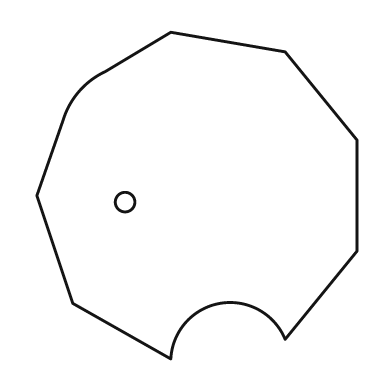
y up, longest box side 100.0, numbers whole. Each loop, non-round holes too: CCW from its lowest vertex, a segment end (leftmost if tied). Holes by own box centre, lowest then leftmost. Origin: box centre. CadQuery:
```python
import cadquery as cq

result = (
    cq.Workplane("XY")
    .moveTo(-8.0, -50.0)
    .threePointArc((7.0, -33.0), (27.0, -44.0))
    .lineTo(49.0, -17.0)
    .lineTo(49.0, 17.0)
    .lineTo(27.0, 44.0)
    .lineTo(-8.0, 50.0)
    .lineTo(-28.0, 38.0)
    .threePointArc((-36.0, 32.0), (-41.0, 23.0))
    .lineTo(-49.0, 0.0)
    .lineTo(-38.0, -33.0)
    .close()
    .moveTo(-22.0, -2.0)
    .circle(3.0)
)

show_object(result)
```